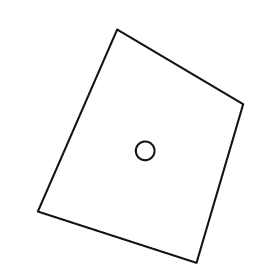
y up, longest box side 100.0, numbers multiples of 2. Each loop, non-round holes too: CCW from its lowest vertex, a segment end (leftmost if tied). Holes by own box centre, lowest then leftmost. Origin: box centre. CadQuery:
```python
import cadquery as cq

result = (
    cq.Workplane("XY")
    .moveTo(24.0, -50.0)
    .lineTo(44.0, 18.0)
    .lineTo(-10.0, 50.0)
    .lineTo(-44.0, -28.0)
    .close()
    .moveTo(2.0, -2.0)
    .circle(4.0)
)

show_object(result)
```